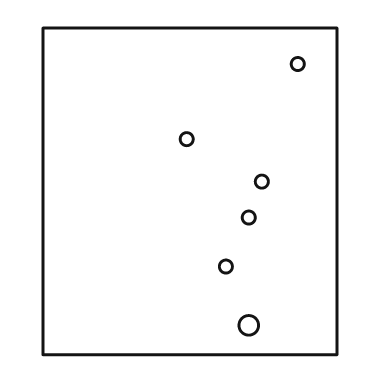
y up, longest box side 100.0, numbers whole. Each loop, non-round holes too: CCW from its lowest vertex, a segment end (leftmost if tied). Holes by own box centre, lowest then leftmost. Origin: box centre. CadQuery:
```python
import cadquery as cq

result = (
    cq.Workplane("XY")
    .moveTo(-45.0, -50.0)
    .lineTo(45.0, -50.0)
    .lineTo(45.0, 50.0)
    .lineTo(-45.0, 50.0)
    .close()
    .moveTo(18.0, -41.0)
    .circle(3.0)
    .moveTo(11.0, -23.0)
    .circle(2.0)
    .moveTo(18.0, -8.0)
    .circle(2.0)
    .moveTo(22.0, 3.0)
    .circle(2.0)
    .moveTo(-1.0, 16.0)
    .circle(2.0)
    .moveTo(33.0, 39.0)
    .circle(2.0)
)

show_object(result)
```